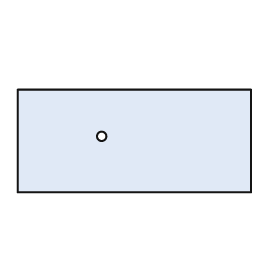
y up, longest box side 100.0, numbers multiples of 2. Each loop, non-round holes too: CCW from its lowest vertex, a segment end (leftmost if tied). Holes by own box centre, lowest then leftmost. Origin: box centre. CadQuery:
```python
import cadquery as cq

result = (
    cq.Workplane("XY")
    .moveTo(-50.0, -22.0)
    .lineTo(50.0, -22.0)
    .lineTo(50.0, 22.0)
    .lineTo(-50.0, 22.0)
    .close()
    .moveTo(-14.0, 2.0)
    .circle(2.0)
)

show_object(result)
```